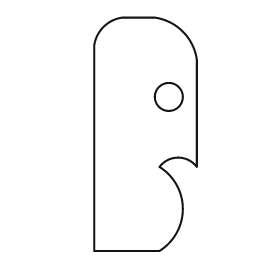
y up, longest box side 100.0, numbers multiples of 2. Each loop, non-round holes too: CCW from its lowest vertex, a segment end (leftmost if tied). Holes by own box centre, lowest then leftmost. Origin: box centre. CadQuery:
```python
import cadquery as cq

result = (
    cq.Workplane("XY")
    .moveTo(-22.0, -50.0)
    .lineTo(6.0, -50.0)
    .threePointArc((16.0, -32.0), (6.0, -14.0))
    .threePointArc((14.0, -10.0), (22.0, -14.0))
    .lineTo(22.0, 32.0)
    .threePointArc((16.0, 44.0), (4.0, 50.0))
    .lineTo(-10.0, 50.0)
    .threePointArc((-18.0, 46.0), (-22.0, 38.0))
    .close()
    .moveTo(10.0, 16.0)
    .circle(6.0)
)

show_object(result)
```